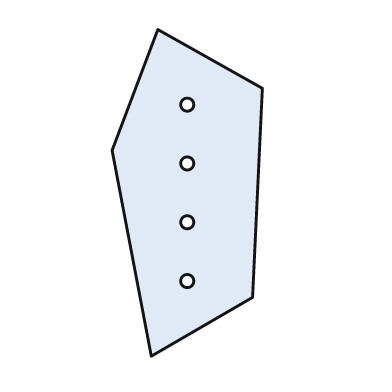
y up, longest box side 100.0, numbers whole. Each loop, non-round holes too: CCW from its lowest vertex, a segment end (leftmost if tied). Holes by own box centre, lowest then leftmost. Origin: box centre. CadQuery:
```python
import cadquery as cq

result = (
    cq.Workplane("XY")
    .moveTo(-11.0, -50.0)
    .lineTo(20.0, -32.0)
    .lineTo(23.0, 32.0)
    .lineTo(-9.0, 50.0)
    .lineTo(-23.0, 13.0)
    .close()
    .moveTo(0.0, -27.0)
    .circle(2.0)
    .moveTo(0.0, -9.0)
    .circle(2.0)
    .moveTo(0.0, 9.0)
    .circle(2.0)
    .moveTo(0.0, 27.0)
    .circle(2.0)
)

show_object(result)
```